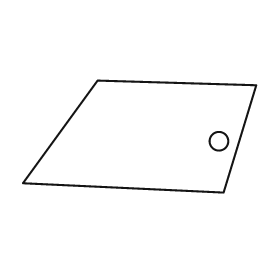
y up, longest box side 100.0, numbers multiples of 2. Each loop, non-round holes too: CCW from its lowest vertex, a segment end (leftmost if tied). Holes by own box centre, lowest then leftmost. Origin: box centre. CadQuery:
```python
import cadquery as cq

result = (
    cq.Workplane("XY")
    .moveTo(36.0, -24.0)
    .lineTo(50.0, 22.0)
    .lineTo(-18.0, 24.0)
    .lineTo(-50.0, -20.0)
    .close()
    .moveTo(34.0, -2.0)
    .circle(4.0)
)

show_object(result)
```